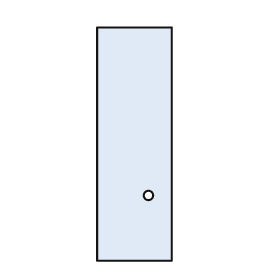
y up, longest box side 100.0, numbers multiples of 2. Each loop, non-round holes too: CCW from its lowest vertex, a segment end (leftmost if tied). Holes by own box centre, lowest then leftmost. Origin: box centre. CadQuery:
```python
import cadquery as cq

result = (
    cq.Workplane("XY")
    .moveTo(-16.0, -50.0)
    .lineTo(16.0, -50.0)
    .lineTo(16.0, 50.0)
    .lineTo(-16.0, 50.0)
    .close()
    .moveTo(6.0, -22.0)
    .circle(2.0)
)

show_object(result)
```